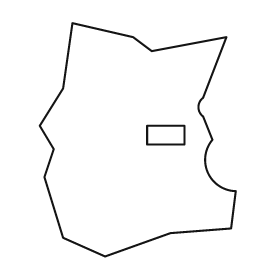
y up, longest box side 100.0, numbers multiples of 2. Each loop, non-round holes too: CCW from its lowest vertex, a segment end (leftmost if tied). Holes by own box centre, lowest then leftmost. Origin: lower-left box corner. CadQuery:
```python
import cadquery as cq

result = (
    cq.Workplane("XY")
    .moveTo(28.0, 0.0)
    .lineTo(56.0, 10.0)
    .lineTo(82.0, 12.0)
    .lineTo(84.0, 28.0)
    .threePointArc((72.0, 36.0), (74.0, 50.0))
    .lineTo(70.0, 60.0)
    .threePointArc((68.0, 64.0), (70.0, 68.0))
    .lineTo(80.0, 94.0)
    .lineTo(48.0, 88.0)
    .lineTo(40.0, 94.0)
    .lineTo(14.0, 100.0)
    .lineTo(10.0, 72.0)
    .lineTo(0.0, 56.0)
    .lineTo(6.0, 46.0)
    .lineTo(2.0, 34.0)
    .lineTo(10.0, 8.0)
    .close()
    .moveTo(46.0, 48.0)
    .lineTo(62.0, 48.0)
    .lineTo(62.0, 56.0)
    .lineTo(46.0, 56.0)
    .close()
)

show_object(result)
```